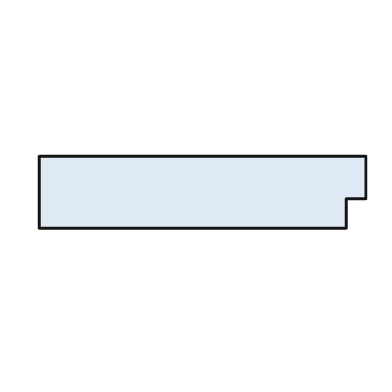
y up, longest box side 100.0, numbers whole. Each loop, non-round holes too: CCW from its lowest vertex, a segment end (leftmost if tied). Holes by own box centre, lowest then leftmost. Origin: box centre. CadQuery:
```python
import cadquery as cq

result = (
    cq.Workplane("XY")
    .moveTo(-50.0, -11.0)
    .lineTo(44.0, -11.0)
    .lineTo(44.0, -2.0)
    .lineTo(50.0, -2.0)
    .lineTo(50.0, 11.0)
    .lineTo(-50.0, 11.0)
    .close()
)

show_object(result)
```